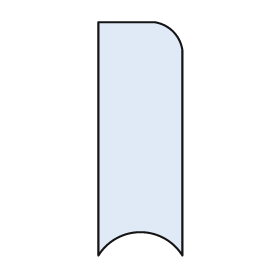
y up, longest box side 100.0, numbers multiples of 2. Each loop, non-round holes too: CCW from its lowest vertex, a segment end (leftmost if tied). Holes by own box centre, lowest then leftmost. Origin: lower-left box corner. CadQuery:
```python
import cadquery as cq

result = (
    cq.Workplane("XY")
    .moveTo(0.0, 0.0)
    .threePointArc((18.0, 10.0), (36.0, 0.0))
    .lineTo(36.0, 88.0)
    .threePointArc((32.0, 96.0), (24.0, 100.0))
    .lineTo(0.0, 100.0)
    .close()
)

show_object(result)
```